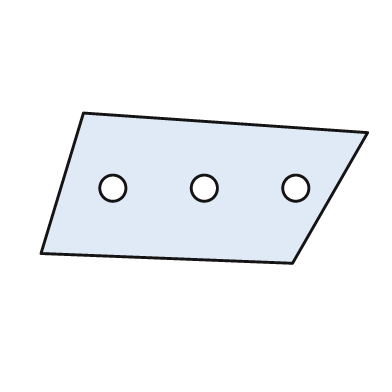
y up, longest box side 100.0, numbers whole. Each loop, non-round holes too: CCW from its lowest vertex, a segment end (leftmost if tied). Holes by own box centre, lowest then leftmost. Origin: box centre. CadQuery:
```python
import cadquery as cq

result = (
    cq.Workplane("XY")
    .moveTo(27.0, -23.0)
    .lineTo(50.0, 17.0)
    .lineTo(-37.0, 23.0)
    .lineTo(-50.0, -20.0)
    .close()
    .moveTo(-28.0, 0.0)
    .circle(4.0)
    .moveTo(0.0, 0.0)
    .circle(4.0)
    .moveTo(28.0, 0.0)
    .circle(4.0)
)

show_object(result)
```